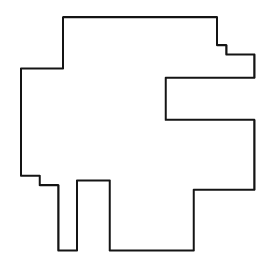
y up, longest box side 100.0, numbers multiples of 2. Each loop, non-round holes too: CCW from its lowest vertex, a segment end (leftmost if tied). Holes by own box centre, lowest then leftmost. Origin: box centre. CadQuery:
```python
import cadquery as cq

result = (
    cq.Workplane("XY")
    .moveTo(-34.0, -50.0)
    .lineTo(-26.0, -50.0)
    .lineTo(-26.0, -20.0)
    .lineTo(-12.0, -20.0)
    .lineTo(-12.0, -50.0)
    .lineTo(24.0, -50.0)
    .lineTo(24.0, -24.0)
    .lineTo(50.0, -24.0)
    .lineTo(50.0, 6.0)
    .lineTo(12.0, 6.0)
    .lineTo(12.0, 24.0)
    .lineTo(50.0, 24.0)
    .lineTo(50.0, 34.0)
    .lineTo(38.0, 34.0)
    .lineTo(38.0, 38.0)
    .lineTo(34.0, 38.0)
    .lineTo(34.0, 50.0)
    .lineTo(-32.0, 50.0)
    .lineTo(-32.0, 28.0)
    .lineTo(-50.0, 28.0)
    .lineTo(-50.0, -18.0)
    .lineTo(-42.0, -18.0)
    .lineTo(-42.0, -22.0)
    .lineTo(-34.0, -22.0)
    .close()
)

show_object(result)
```